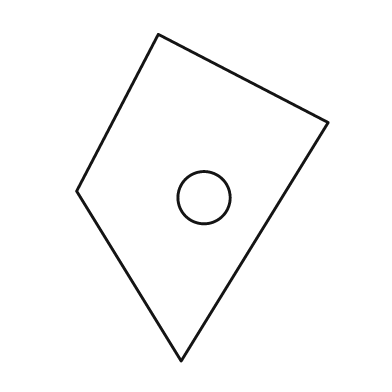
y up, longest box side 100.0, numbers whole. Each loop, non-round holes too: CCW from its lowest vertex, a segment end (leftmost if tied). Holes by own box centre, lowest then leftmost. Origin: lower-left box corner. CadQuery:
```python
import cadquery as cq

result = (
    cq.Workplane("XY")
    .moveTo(32.0, 0.0)
    .lineTo(77.0, 73.0)
    .lineTo(25.0, 100.0)
    .lineTo(0.0, 52.0)
    .close()
    .moveTo(39.0, 50.0)
    .circle(8.0)
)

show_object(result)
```